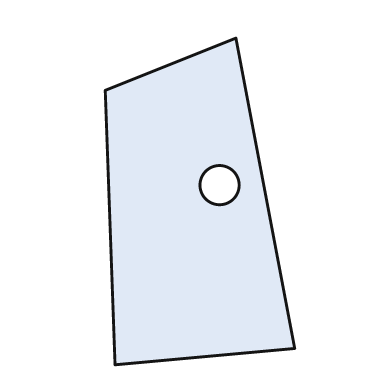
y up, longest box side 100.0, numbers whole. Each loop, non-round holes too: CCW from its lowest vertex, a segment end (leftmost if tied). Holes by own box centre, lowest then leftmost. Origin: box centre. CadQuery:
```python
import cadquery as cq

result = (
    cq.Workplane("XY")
    .moveTo(-26.0, -50.0)
    .lineTo(29.0, -45.0)
    .lineTo(11.0, 50.0)
    .lineTo(-29.0, 34.0)
    .close()
    .moveTo(6.0, 5.0)
    .circle(6.0)
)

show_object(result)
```